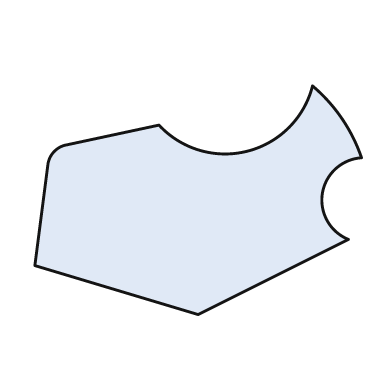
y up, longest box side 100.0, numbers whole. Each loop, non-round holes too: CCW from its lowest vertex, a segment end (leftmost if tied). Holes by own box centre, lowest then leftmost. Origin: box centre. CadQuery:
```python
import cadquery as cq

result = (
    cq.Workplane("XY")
    .moveTo(0.0, -35.0)
    .lineTo(46.0, -12.0)
    .threePointArc((38.0, 2.0), (50.0, 13.0))
    .threePointArc((44.0, 25.0), (35.0, 35.0))
    .threePointArc((15.0, 15.0), (-12.0, 23.0))
    .lineTo(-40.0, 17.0)
    .threePointArc((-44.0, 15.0), (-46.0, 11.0))
    .lineTo(-50.0, -20.0)
    .close()
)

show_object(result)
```